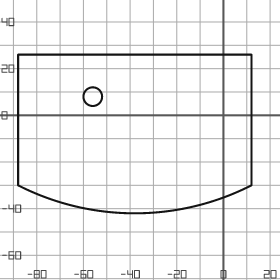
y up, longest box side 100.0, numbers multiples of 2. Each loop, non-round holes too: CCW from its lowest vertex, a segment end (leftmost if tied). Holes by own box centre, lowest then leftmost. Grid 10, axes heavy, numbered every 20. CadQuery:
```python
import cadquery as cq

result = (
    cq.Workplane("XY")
    .moveTo(-88.0, -30.0)
    .threePointArc((-38.0, -42.0), (12.0, -30.0))
    .lineTo(12.0, 26.0)
    .lineTo(-88.0, 26.0)
    .close()
    .moveTo(-56.0, 8.0)
    .circle(4.0)
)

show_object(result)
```